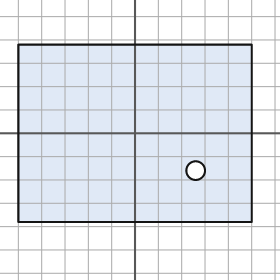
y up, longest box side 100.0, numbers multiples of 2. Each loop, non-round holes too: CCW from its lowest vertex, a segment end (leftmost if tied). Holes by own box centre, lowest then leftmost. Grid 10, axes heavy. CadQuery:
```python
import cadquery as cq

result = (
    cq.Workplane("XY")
    .moveTo(-50.0, -38.0)
    .lineTo(50.0, -38.0)
    .lineTo(50.0, 38.0)
    .lineTo(-50.0, 38.0)
    .close()
    .moveTo(26.0, -16.0)
    .circle(4.0)
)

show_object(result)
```